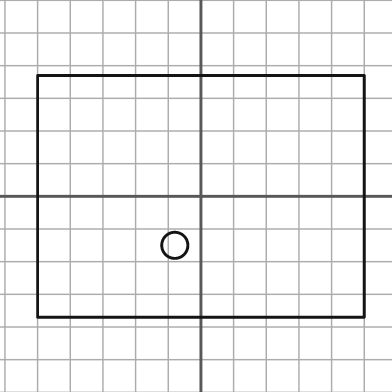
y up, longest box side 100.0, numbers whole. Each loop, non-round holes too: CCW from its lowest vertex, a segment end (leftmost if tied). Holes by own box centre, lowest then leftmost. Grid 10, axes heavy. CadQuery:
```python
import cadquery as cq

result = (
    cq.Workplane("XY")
    .moveTo(-50.0, -37.0)
    .lineTo(50.0, -37.0)
    .lineTo(50.0, 37.0)
    .lineTo(-50.0, 37.0)
    .close()
    .moveTo(-8.0, -15.0)
    .circle(4.0)
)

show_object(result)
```